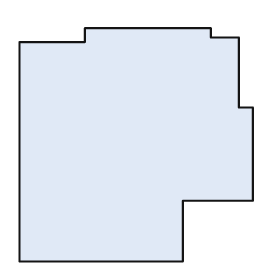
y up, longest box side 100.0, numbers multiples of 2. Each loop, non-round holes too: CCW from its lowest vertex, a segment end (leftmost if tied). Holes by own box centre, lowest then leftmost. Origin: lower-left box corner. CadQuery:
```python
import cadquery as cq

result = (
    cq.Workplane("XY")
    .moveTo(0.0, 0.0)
    .lineTo(70.0, 0.0)
    .lineTo(70.0, 26.0)
    .lineTo(100.0, 26.0)
    .lineTo(100.0, 66.0)
    .lineTo(94.0, 66.0)
    .lineTo(94.0, 96.0)
    .lineTo(82.0, 96.0)
    .lineTo(82.0, 100.0)
    .lineTo(28.0, 100.0)
    .lineTo(28.0, 94.0)
    .lineTo(0.0, 94.0)
    .close()
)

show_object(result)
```